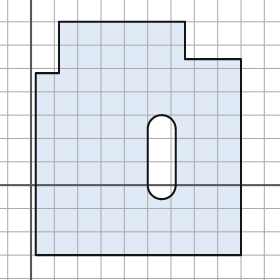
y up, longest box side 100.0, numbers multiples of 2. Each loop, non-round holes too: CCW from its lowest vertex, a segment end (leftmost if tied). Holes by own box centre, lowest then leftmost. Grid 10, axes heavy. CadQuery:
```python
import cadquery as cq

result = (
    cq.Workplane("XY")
    .moveTo(2.0, -30.0)
    .lineTo(90.0, -30.0)
    .lineTo(90.0, 54.0)
    .lineTo(66.0, 54.0)
    .lineTo(66.0, 70.0)
    .lineTo(12.0, 70.0)
    .lineTo(12.0, 48.0)
    .lineTo(2.0, 48.0)
    .close()
    .moveTo(50.0, 0.0)
    .threePointArc((56.0, -6.0), (62.0, 0.0))
    .lineTo(62.0, 24.0)
    .threePointArc((56.0, 30.0), (50.0, 24.0))
    .close()
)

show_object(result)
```